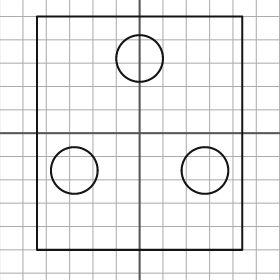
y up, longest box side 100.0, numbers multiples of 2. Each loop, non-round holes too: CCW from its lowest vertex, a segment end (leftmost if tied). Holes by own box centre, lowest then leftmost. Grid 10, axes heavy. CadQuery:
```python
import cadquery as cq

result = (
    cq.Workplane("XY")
    .moveTo(-44.0, -50.0)
    .lineTo(44.0, -50.0)
    .lineTo(44.0, 50.0)
    .lineTo(-44.0, 50.0)
    .close()
    .moveTo(-28.0, -16.0)
    .circle(10.0)
    .moveTo(28.0, -16.0)
    .circle(10.0)
    .moveTo(0.0, 32.0)
    .circle(10.0)
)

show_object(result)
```